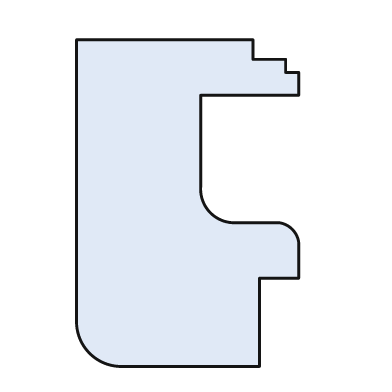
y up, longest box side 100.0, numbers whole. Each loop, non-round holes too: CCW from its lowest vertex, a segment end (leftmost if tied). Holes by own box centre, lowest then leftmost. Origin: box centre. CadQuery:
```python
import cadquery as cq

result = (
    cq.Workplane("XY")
    .moveTo(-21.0, -50.0)
    .lineTo(22.0, -50.0)
    .lineTo(22.0, -23.0)
    .lineTo(34.0, -23.0)
    .lineTo(34.0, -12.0)
    .threePointArc((32.0, -8.0), (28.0, -6.0))
    .lineTo(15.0, -6.0)
    .threePointArc((7.0, -3.0), (4.0, 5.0))
    .lineTo(4.0, 33.0)
    .lineTo(34.0, 33.0)
    .lineTo(34.0, 40.0)
    .lineTo(30.0, 40.0)
    .lineTo(30.0, 44.0)
    .lineTo(20.0, 44.0)
    .lineTo(20.0, 50.0)
    .lineTo(-34.0, 50.0)
    .lineTo(-34.0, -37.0)
    .threePointArc((-30.0, -46.0), (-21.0, -50.0))
    .close()
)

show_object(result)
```